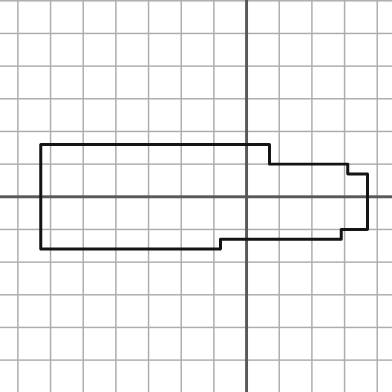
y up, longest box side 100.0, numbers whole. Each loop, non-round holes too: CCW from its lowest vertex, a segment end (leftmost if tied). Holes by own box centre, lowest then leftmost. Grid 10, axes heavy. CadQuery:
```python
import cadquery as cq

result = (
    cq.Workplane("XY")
    .moveTo(-63.0, -16.0)
    .lineTo(-8.0, -16.0)
    .lineTo(-8.0, -13.0)
    .lineTo(29.0, -13.0)
    .lineTo(29.0, -10.0)
    .lineTo(37.0, -10.0)
    .lineTo(37.0, 7.0)
    .lineTo(31.0, 7.0)
    .lineTo(31.0, 10.0)
    .lineTo(7.0, 10.0)
    .lineTo(7.0, 16.0)
    .lineTo(-63.0, 16.0)
    .close()
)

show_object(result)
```